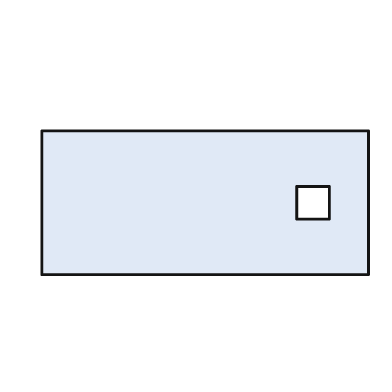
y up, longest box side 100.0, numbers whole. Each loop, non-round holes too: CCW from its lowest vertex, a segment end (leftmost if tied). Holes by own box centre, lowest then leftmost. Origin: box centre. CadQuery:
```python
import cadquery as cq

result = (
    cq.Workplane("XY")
    .moveTo(-50.0, -22.0)
    .lineTo(50.0, -22.0)
    .lineTo(50.0, 22.0)
    .lineTo(-50.0, 22.0)
    .close()
    .moveTo(28.0, -5.0)
    .lineTo(38.0, -5.0)
    .lineTo(38.0, 5.0)
    .lineTo(28.0, 5.0)
    .close()
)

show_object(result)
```